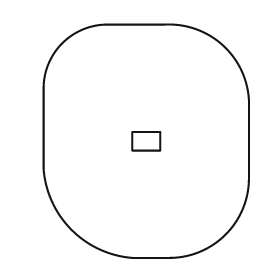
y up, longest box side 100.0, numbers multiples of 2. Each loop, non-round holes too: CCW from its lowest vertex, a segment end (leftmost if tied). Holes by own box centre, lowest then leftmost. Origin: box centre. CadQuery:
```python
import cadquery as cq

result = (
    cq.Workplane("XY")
    .moveTo(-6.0, -50.0)
    .lineTo(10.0, -50.0)
    .threePointArc((34.0, -40.0), (44.0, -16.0))
    .lineTo(44.0, 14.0)
    .threePointArc((34.0, 40.0), (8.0, 50.0))
    .lineTo(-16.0, 50.0)
    .threePointArc((-36.0, 42.0), (-44.0, 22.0))
    .lineTo(-44.0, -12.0)
    .threePointArc((-32.0, -38.0), (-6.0, -50.0))
    .close()
    .moveTo(-6.0, -4.0)
    .lineTo(6.0, -4.0)
    .lineTo(6.0, 4.0)
    .lineTo(-6.0, 4.0)
    .close()
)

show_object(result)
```